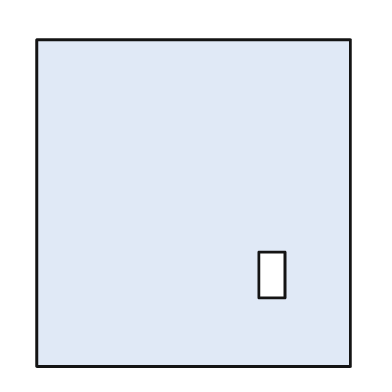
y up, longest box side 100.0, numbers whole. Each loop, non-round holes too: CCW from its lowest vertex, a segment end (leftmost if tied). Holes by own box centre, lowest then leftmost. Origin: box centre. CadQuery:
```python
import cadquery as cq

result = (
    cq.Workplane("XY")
    .moveTo(-48.0, -50.0)
    .lineTo(48.0, -50.0)
    .lineTo(48.0, 50.0)
    .lineTo(-48.0, 50.0)
    .close()
    .moveTo(20.0, -29.0)
    .lineTo(28.0, -29.0)
    .lineTo(28.0, -15.0)
    .lineTo(20.0, -15.0)
    .close()
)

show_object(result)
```